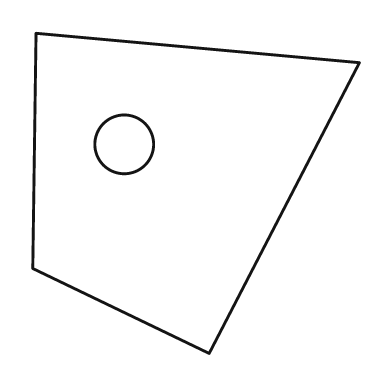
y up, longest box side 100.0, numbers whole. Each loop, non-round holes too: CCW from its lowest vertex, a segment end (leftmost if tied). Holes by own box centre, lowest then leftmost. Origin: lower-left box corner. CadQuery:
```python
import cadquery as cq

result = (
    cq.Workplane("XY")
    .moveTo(54.0, 0.0)
    .lineTo(100.0, 89.0)
    .lineTo(1.0, 98.0)
    .lineTo(0.0, 26.0)
    .close()
    .moveTo(28.0, 64.0)
    .circle(9.0)
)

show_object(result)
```